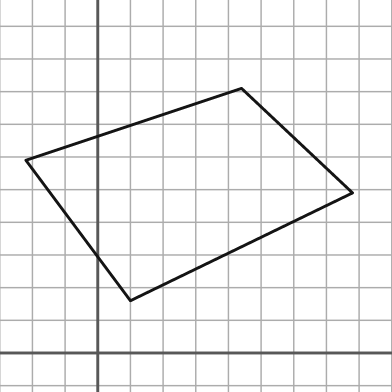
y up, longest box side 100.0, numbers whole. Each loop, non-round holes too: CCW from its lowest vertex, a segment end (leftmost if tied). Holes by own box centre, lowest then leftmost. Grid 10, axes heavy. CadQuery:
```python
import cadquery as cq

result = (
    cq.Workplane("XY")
    .moveTo(10.0, 16.0)
    .lineTo(78.0, 49.0)
    .lineTo(44.0, 81.0)
    .lineTo(-22.0, 59.0)
    .close()
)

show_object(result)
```